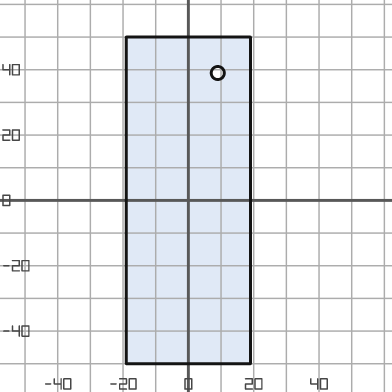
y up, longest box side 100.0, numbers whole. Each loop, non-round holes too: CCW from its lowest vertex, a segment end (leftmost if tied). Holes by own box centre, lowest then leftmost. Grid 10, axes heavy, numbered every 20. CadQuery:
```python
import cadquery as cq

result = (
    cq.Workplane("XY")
    .moveTo(-19.0, -50.0)
    .lineTo(19.0, -50.0)
    .lineTo(19.0, 50.0)
    .lineTo(-19.0, 50.0)
    .close()
    .moveTo(9.0, 39.0)
    .circle(2.0)
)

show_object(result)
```